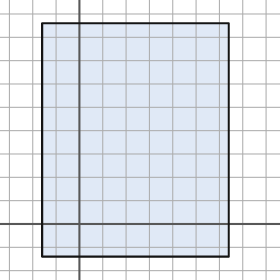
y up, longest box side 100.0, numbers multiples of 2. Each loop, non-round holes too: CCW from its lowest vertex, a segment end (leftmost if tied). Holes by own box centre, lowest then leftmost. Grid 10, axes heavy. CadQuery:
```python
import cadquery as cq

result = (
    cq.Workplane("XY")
    .moveTo(-16.0, -14.0)
    .lineTo(64.0, -14.0)
    .lineTo(64.0, 86.0)
    .lineTo(-16.0, 86.0)
    .close()
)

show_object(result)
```